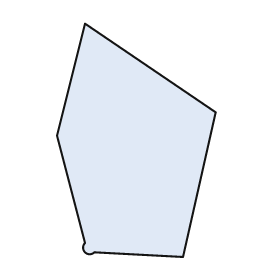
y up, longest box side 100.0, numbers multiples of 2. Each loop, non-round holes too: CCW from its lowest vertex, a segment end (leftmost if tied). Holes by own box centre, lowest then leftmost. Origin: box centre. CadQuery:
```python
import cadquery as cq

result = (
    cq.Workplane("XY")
    .moveTo(20.0, -50.0)
    .lineTo(34.0, 12.0)
    .lineTo(-22.0, 50.0)
    .lineTo(-34.0, 2.0)
    .lineTo(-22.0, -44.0)
    .threePointArc((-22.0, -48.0), (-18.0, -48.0))
    .close()
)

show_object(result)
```